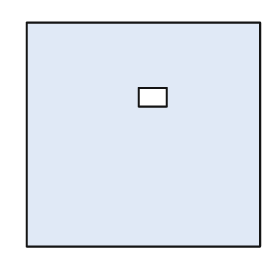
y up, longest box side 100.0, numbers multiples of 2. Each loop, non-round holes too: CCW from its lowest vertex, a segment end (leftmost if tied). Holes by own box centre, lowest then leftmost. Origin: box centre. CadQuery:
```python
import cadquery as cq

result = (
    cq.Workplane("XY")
    .moveTo(-50.0, -48.0)
    .lineTo(50.0, -48.0)
    .lineTo(50.0, 48.0)
    .lineTo(-50.0, 48.0)
    .close()
    .moveTo(-2.0, 12.0)
    .lineTo(10.0, 12.0)
    .lineTo(10.0, 20.0)
    .lineTo(-2.0, 20.0)
    .close()
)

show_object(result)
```